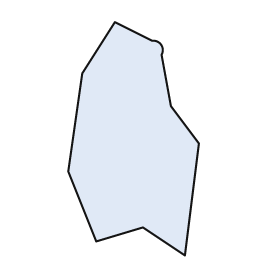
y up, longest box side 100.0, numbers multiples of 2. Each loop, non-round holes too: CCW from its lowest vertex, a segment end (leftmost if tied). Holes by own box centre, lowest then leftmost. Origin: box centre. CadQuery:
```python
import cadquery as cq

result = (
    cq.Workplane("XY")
    .moveTo(22.0, -50.0)
    .lineTo(28.0, -2.0)
    .lineTo(16.0, 14.0)
    .lineTo(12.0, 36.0)
    .threePointArc((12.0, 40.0), (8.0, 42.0))
    .lineTo(-8.0, 50.0)
    .lineTo(-22.0, 28.0)
    .lineTo(-28.0, -14.0)
    .lineTo(-16.0, -44.0)
    .lineTo(4.0, -38.0)
    .close()
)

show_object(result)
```